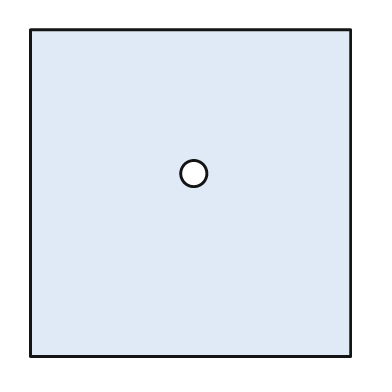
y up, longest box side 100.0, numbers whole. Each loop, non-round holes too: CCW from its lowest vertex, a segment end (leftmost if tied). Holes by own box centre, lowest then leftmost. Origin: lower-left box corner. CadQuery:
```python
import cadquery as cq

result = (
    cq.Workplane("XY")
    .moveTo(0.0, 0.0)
    .lineTo(98.0, 0.0)
    .lineTo(98.0, 100.0)
    .lineTo(0.0, 100.0)
    .close()
    .moveTo(50.0, 56.0)
    .circle(4.0)
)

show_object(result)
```